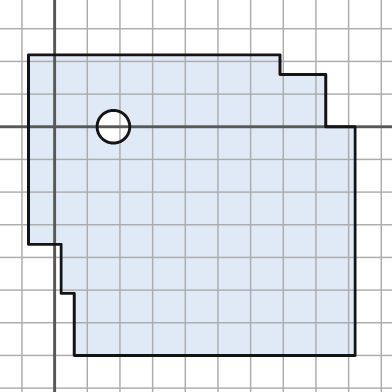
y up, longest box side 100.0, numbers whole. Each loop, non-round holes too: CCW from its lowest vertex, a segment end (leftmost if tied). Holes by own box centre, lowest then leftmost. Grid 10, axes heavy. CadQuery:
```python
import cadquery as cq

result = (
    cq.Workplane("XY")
    .moveTo(6.0, -70.0)
    .lineTo(92.0, -70.0)
    .lineTo(92.0, 0.0)
    .lineTo(83.0, 0.0)
    .lineTo(83.0, 16.0)
    .lineTo(69.0, 16.0)
    .lineTo(69.0, 22.0)
    .lineTo(-8.0, 22.0)
    .lineTo(-8.0, -36.0)
    .lineTo(2.0, -36.0)
    .lineTo(2.0, -51.0)
    .lineTo(6.0, -51.0)
    .close()
    .moveTo(18.0, 0.0)
    .circle(5.0)
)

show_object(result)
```